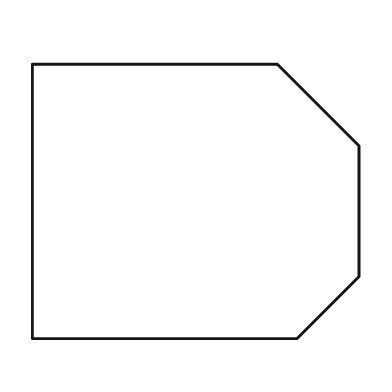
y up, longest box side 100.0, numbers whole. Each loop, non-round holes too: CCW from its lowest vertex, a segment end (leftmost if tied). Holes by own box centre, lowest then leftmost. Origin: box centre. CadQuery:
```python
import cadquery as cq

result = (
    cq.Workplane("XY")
    .moveTo(-50.0, -42.0)
    .lineTo(31.0, -42.0)
    .lineTo(50.0, -23.0)
    .lineTo(50.0, 17.0)
    .lineTo(25.0, 42.0)
    .lineTo(-50.0, 42.0)
    .close()
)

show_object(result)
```